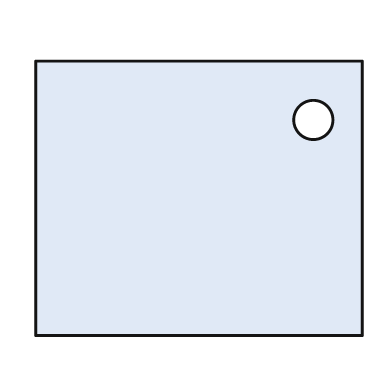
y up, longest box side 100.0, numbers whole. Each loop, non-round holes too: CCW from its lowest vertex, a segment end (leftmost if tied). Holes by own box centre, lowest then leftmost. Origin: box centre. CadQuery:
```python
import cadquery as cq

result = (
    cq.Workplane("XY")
    .moveTo(-50.0, -42.0)
    .lineTo(50.0, -42.0)
    .lineTo(50.0, 42.0)
    .lineTo(-50.0, 42.0)
    .close()
    .moveTo(35.0, 24.0)
    .circle(6.0)
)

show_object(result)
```